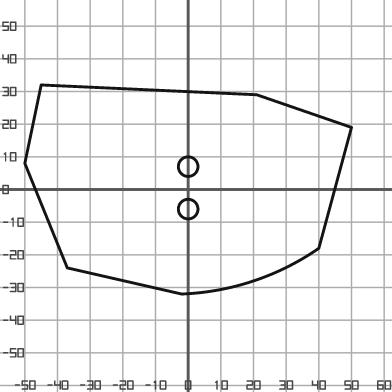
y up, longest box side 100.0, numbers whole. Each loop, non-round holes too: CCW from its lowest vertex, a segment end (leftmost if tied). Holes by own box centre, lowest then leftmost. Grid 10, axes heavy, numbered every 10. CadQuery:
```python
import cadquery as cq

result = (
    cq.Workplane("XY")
    .moveTo(-2.0, -32.0)
    .threePointArc((20.0, -28.0), (40.0, -18.0))
    .lineTo(50.0, 19.0)
    .lineTo(21.0, 29.0)
    .lineTo(-45.0, 32.0)
    .lineTo(-50.0, 8.0)
    .lineTo(-37.0, -24.0)
    .close()
    .moveTo(0.0, -6.0)
    .circle(3.0)
    .moveTo(0.0, 7.0)
    .circle(3.0)
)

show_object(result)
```